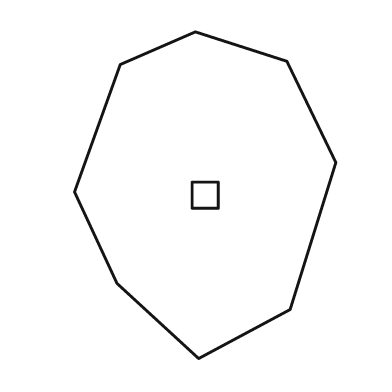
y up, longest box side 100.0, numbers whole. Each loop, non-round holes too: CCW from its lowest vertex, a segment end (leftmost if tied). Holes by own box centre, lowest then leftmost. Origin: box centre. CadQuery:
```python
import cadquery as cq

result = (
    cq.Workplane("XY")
    .moveTo(-2.0, -50.0)
    .lineTo(26.0, -35.0)
    .lineTo(40.0, 10.0)
    .lineTo(25.0, 41.0)
    .lineTo(-3.0, 50.0)
    .lineTo(-26.0, 40.0)
    .lineTo(-40.0, 1.0)
    .lineTo(-27.0, -27.0)
    .close()
    .moveTo(-4.0, -4.0)
    .lineTo(4.0, -4.0)
    .lineTo(4.0, 4.0)
    .lineTo(-4.0, 4.0)
    .close()
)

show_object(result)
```